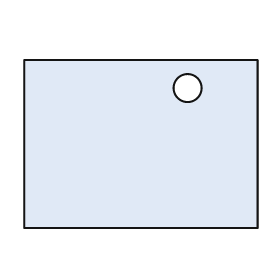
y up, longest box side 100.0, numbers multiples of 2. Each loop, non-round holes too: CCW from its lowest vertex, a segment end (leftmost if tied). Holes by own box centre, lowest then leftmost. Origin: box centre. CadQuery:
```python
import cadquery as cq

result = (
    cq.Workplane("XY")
    .moveTo(-50.0, -36.0)
    .lineTo(50.0, -36.0)
    .lineTo(50.0, 36.0)
    .lineTo(-50.0, 36.0)
    .close()
    .moveTo(20.0, 24.0)
    .circle(6.0)
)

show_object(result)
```